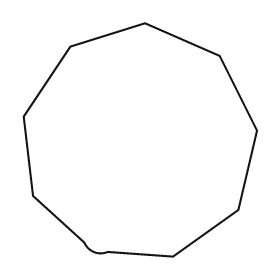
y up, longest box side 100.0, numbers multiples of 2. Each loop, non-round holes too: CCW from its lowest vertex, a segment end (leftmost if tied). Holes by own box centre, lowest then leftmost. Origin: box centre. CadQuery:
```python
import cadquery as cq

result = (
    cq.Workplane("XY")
    .moveTo(14.0, -50.0)
    .lineTo(42.0, -30.0)
    .lineTo(50.0, 4.0)
    .lineTo(34.0, 36.0)
    .lineTo(2.0, 50.0)
    .lineTo(-30.0, 40.0)
    .lineTo(-50.0, 10.0)
    .lineTo(-46.0, -24.0)
    .lineTo(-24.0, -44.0)
    .threePointArc((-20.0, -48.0), (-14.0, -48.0))
    .close()
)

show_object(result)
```